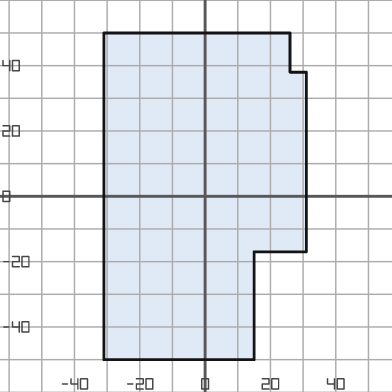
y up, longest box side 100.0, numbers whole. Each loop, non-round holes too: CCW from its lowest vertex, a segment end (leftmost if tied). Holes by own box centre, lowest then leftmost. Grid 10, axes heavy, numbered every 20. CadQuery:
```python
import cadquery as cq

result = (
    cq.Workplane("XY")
    .moveTo(-31.0, -50.0)
    .lineTo(15.0, -50.0)
    .lineTo(15.0, -17.0)
    .lineTo(31.0, -17.0)
    .lineTo(31.0, 38.0)
    .lineTo(26.0, 38.0)
    .lineTo(26.0, 50.0)
    .lineTo(-31.0, 50.0)
    .close()
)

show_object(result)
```